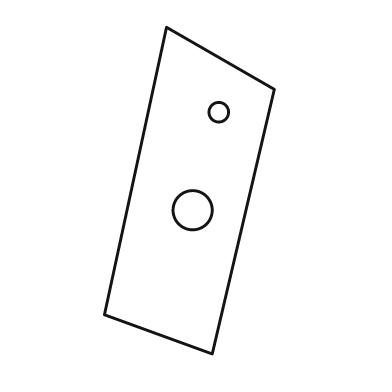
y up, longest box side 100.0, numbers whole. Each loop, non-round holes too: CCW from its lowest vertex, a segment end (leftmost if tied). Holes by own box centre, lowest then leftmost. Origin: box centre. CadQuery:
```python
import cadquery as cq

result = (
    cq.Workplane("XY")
    .moveTo(7.0, -50.0)
    .lineTo(26.0, 31.0)
    .lineTo(-7.0, 50.0)
    .lineTo(-26.0, -38.0)
    .close()
    .moveTo(1.0, -6.0)
    .circle(6.0)
    .moveTo(9.0, 24.0)
    .circle(3.0)
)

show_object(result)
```